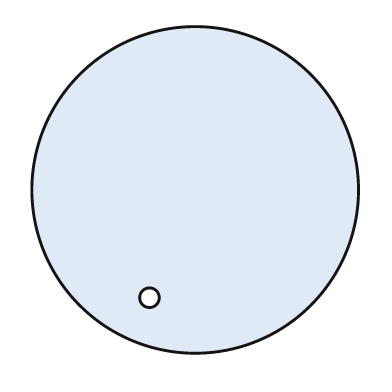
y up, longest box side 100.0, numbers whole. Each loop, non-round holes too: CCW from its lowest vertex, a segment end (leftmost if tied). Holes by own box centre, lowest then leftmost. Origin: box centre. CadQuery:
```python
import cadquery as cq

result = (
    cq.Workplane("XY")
    .moveTo(0.0, 0.0)
    .circle(50.0)
    .moveTo(-14.0, -33.0)
    .circle(3.0)
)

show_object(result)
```